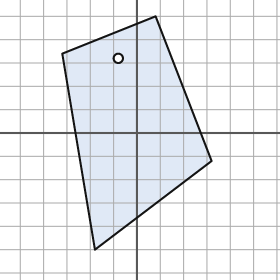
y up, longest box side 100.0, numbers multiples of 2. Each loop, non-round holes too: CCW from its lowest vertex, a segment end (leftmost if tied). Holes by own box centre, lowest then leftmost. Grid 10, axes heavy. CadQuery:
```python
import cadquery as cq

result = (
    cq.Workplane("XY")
    .moveTo(-18.0, -50.0)
    .lineTo(32.0, -12.0)
    .lineTo(8.0, 50.0)
    .lineTo(-32.0, 34.0)
    .close()
    .moveTo(-8.0, 32.0)
    .circle(2.0)
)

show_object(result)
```